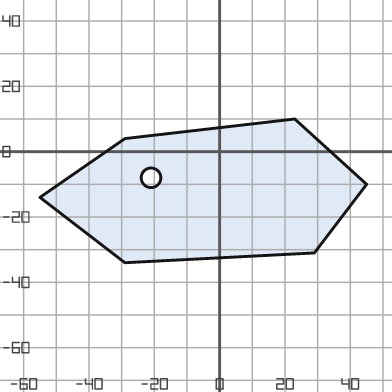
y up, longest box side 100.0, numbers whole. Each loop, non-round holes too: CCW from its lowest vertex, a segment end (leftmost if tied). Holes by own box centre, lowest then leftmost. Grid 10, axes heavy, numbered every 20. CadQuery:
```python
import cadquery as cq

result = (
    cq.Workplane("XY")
    .moveTo(-29.0, -34.0)
    .lineTo(29.0, -31.0)
    .lineTo(45.0, -10.0)
    .lineTo(23.0, 10.0)
    .lineTo(-29.0, 4.0)
    .lineTo(-55.0, -14.0)
    .close()
    .moveTo(-21.0, -8.0)
    .circle(3.0)
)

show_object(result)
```